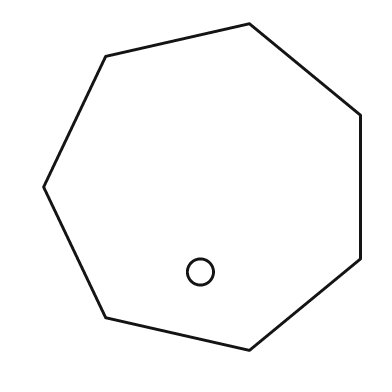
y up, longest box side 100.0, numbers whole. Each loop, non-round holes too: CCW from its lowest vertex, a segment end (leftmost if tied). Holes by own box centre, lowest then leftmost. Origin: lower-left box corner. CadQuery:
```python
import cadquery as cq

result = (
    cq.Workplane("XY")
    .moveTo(63.0, 0.0)
    .lineTo(97.0, 28.0)
    .lineTo(97.0, 72.0)
    .lineTo(63.0, 100.0)
    .lineTo(19.0, 90.0)
    .lineTo(0.0, 50.0)
    .lineTo(19.0, 10.0)
    .close()
    .moveTo(48.0, 24.0)
    .circle(4.0)
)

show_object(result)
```